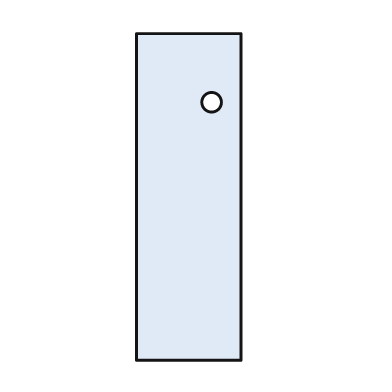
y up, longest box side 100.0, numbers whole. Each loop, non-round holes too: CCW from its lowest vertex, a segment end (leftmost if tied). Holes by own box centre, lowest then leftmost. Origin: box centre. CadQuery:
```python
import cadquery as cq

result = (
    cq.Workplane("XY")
    .moveTo(-16.0, -50.0)
    .lineTo(16.0, -50.0)
    .lineTo(16.0, 50.0)
    .lineTo(-16.0, 50.0)
    .close()
    .moveTo(7.0, 29.0)
    .circle(3.0)
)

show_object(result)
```